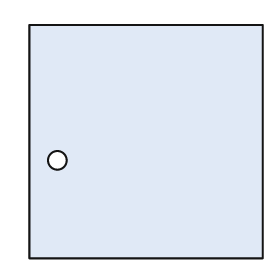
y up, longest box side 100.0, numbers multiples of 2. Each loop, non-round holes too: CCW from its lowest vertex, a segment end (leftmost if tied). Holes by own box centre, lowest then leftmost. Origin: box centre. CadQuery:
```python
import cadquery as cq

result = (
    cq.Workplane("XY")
    .moveTo(-50.0, -50.0)
    .lineTo(50.0, -50.0)
    .lineTo(50.0, 50.0)
    .lineTo(-50.0, 50.0)
    .close()
    .moveTo(-38.0, -8.0)
    .circle(4.0)
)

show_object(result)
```